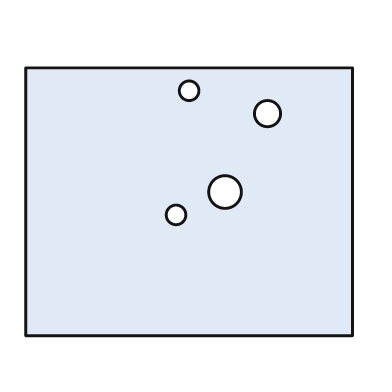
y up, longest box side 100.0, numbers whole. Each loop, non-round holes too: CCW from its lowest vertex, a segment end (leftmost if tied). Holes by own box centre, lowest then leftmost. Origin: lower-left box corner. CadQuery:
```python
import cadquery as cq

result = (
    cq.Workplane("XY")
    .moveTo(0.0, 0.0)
    .lineTo(100.0, 0.0)
    .lineTo(100.0, 82.0)
    .lineTo(0.0, 82.0)
    .close()
    .moveTo(46.0, 37.0)
    .circle(3.0)
    .moveTo(61.0, 44.0)
    .circle(5.0)
    .moveTo(74.0, 68.0)
    .circle(4.0)
    .moveTo(50.0, 75.0)
    .circle(3.0)
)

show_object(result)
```